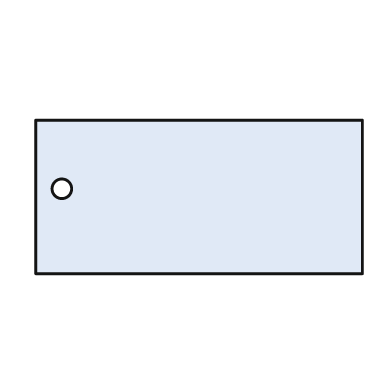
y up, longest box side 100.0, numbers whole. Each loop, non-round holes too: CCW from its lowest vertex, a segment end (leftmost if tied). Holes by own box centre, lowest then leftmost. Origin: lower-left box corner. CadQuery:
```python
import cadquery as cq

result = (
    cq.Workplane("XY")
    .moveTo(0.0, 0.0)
    .lineTo(100.0, 0.0)
    .lineTo(100.0, 47.0)
    .lineTo(0.0, 47.0)
    .close()
    .moveTo(8.0, 26.0)
    .circle(3.0)
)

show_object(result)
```